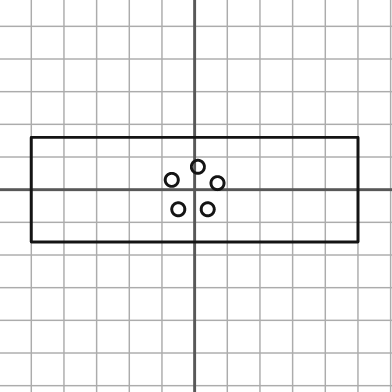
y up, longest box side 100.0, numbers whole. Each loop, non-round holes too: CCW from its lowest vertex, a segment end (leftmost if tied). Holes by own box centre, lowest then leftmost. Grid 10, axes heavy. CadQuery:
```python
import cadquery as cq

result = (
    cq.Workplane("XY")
    .moveTo(-50.0, -16.0)
    .lineTo(50.0, -16.0)
    .lineTo(50.0, 16.0)
    .lineTo(-50.0, 16.0)
    .close()
    .moveTo(-5.0, -6.0)
    .circle(2.0)
    .moveTo(4.0, -6.0)
    .circle(2.0)
    .moveTo(7.0, 2.0)
    .circle(2.0)
    .moveTo(-7.0, 3.0)
    .circle(2.0)
    .moveTo(1.0, 7.0)
    .circle(2.0)
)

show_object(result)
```